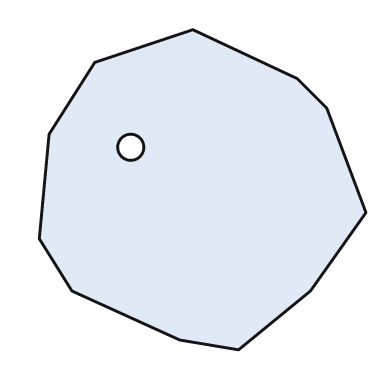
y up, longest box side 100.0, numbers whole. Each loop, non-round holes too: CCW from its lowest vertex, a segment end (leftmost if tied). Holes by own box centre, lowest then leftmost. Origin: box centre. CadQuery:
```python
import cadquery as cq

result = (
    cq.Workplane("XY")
    .moveTo(11.0, -49.0)
    .lineTo(33.0, -31.0)
    .lineTo(50.0, -7.0)
    .lineTo(38.0, 25.0)
    .lineTo(29.0, 34.0)
    .lineTo(-3.0, 49.0)
    .lineTo(-33.0, 39.0)
    .lineTo(-47.0, 17.0)
    .lineTo(-50.0, -15.0)
    .lineTo(-40.0, -31.0)
    .lineTo(-7.0, -46.0)
    .close()
    .moveTo(-22.0, 13.0)
    .circle(4.0)
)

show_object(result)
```